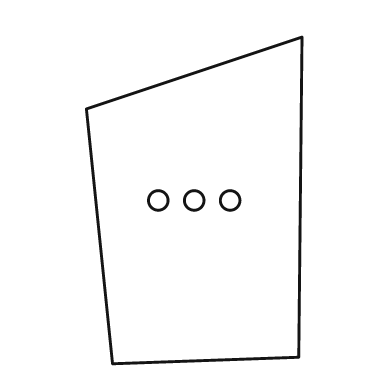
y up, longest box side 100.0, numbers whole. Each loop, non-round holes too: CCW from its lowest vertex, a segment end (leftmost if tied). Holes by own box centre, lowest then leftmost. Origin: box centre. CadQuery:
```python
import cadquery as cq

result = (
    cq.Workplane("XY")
    .moveTo(-25.0, -50.0)
    .lineTo(32.0, -48.0)
    .lineTo(33.0, 50.0)
    .lineTo(-33.0, 28.0)
    .close()
    .moveTo(-11.0, 0.0)
    .circle(3.0)
    .moveTo(0.0, 0.0)
    .circle(3.0)
    .moveTo(11.0, 0.0)
    .circle(3.0)
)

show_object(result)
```